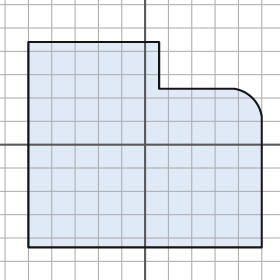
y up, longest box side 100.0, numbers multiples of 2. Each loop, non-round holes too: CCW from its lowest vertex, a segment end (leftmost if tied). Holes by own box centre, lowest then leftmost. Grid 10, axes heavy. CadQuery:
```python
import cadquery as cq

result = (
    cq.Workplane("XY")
    .moveTo(-50.0, -44.0)
    .lineTo(50.0, -44.0)
    .lineTo(50.0, 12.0)
    .threePointArc((46.0, 20.0), (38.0, 24.0))
    .lineTo(6.0, 24.0)
    .lineTo(6.0, 44.0)
    .lineTo(-50.0, 44.0)
    .close()
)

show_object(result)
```